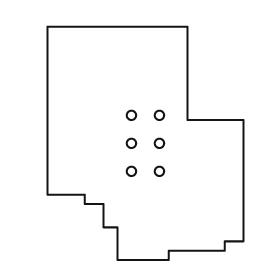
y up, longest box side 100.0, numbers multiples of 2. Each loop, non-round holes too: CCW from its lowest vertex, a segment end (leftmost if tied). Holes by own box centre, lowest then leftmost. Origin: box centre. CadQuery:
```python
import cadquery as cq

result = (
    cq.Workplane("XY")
    .moveTo(-12.0, -50.0)
    .lineTo(10.0, -50.0)
    .lineTo(10.0, -46.0)
    .lineTo(34.0, -46.0)
    .lineTo(34.0, -42.0)
    .lineTo(42.0, -42.0)
    .lineTo(42.0, 10.0)
    .lineTo(18.0, 10.0)
    .lineTo(18.0, 50.0)
    .lineTo(-42.0, 50.0)
    .lineTo(-42.0, -22.0)
    .lineTo(-26.0, -22.0)
    .lineTo(-26.0, -26.0)
    .lineTo(-18.0, -26.0)
    .lineTo(-18.0, -36.0)
    .lineTo(-12.0, -36.0)
    .close()
    .moveTo(-6.0, -12.0)
    .circle(2.0)
    .moveTo(6.0, -12.0)
    .circle(2.0)
    .moveTo(-6.0, 0.0)
    .circle(2.0)
    .moveTo(6.0, 0.0)
    .circle(2.0)
    .moveTo(-6.0, 12.0)
    .circle(2.0)
    .moveTo(6.0, 12.0)
    .circle(2.0)
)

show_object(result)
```